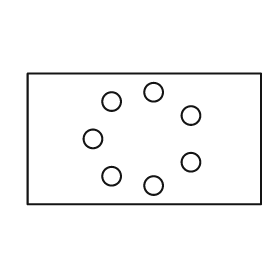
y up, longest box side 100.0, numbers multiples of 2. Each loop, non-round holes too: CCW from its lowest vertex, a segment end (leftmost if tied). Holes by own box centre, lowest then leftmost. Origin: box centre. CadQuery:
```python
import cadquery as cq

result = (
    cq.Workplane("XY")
    .moveTo(-50.0, -28.0)
    .lineTo(50.0, -28.0)
    .lineTo(50.0, 28.0)
    .lineTo(-50.0, 28.0)
    .close()
    .moveTo(4.0, -20.0)
    .circle(4.0)
    .moveTo(-14.0, -16.0)
    .circle(4.0)
    .moveTo(20.0, -10.0)
    .circle(4.0)
    .moveTo(-22.0, 0.0)
    .circle(4.0)
    .moveTo(20.0, 10.0)
    .circle(4.0)
    .moveTo(-14.0, 16.0)
    .circle(4.0)
    .moveTo(4.0, 20.0)
    .circle(4.0)
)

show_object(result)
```